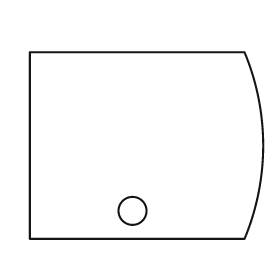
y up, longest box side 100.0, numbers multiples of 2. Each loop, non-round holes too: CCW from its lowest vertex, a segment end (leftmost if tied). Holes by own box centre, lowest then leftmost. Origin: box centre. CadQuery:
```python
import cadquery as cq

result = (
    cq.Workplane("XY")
    .moveTo(-50.0, -40.0)
    .lineTo(42.0, -40.0)
    .threePointArc((50.0, 0.0), (42.0, 40.0))
    .lineTo(-50.0, 40.0)
    .close()
    .moveTo(-6.0, -28.0)
    .circle(6.0)
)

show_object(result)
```